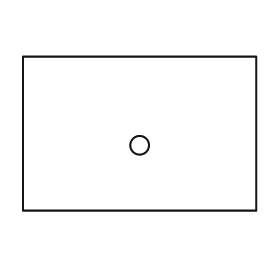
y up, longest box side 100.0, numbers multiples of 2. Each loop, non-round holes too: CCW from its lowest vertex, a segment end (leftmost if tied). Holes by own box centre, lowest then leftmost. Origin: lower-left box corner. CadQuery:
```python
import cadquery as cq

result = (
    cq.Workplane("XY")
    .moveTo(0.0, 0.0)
    .lineTo(100.0, 0.0)
    .lineTo(100.0, 66.0)
    .lineTo(0.0, 66.0)
    .close()
    .moveTo(50.0, 28.0)
    .circle(4.0)
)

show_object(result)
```